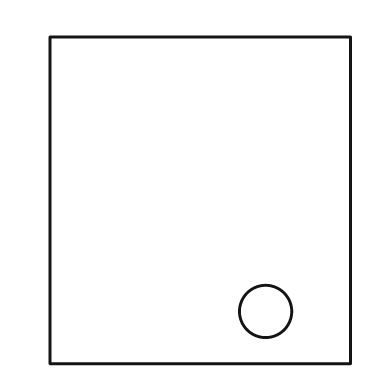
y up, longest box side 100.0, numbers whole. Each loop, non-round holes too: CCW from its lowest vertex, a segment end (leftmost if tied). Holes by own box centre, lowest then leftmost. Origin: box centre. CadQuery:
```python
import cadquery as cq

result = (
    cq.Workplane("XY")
    .moveTo(-46.0, -50.0)
    .lineTo(46.0, -50.0)
    .lineTo(46.0, 50.0)
    .lineTo(-46.0, 50.0)
    .close()
    .moveTo(20.0, -34.0)
    .circle(8.0)
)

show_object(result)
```